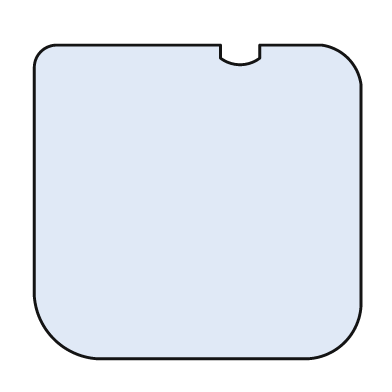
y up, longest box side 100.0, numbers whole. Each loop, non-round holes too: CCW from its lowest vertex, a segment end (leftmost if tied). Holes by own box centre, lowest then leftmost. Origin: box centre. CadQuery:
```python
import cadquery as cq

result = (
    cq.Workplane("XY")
    .moveTo(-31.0, -48.0)
    .lineTo(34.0, -48.0)
    .threePointArc((45.0, -43.0), (50.0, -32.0))
    .lineTo(50.0, 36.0)
    .threePointArc((46.0, 44.0), (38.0, 48.0))
    .lineTo(19.0, 48.0)
    .lineTo(19.0, 44.0)
    .threePointArc((13.0, 42.0), (7.0, 44.0))
    .lineTo(7.0, 48.0)
    .lineTo(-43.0, 48.0)
    .threePointArc((-48.0, 46.0), (-50.0, 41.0))
    .lineTo(-50.0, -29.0)
    .threePointArc((-44.0, -42.0), (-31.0, -48.0))
    .close()
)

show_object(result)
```